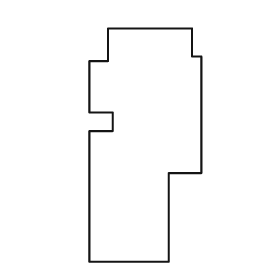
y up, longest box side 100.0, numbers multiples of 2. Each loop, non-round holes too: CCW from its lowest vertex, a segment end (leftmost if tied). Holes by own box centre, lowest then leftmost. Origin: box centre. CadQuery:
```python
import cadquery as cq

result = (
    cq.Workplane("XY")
    .moveTo(-24.0, -50.0)
    .lineTo(10.0, -50.0)
    .lineTo(10.0, -12.0)
    .lineTo(24.0, -12.0)
    .lineTo(24.0, 38.0)
    .lineTo(20.0, 38.0)
    .lineTo(20.0, 50.0)
    .lineTo(-16.0, 50.0)
    .lineTo(-16.0, 36.0)
    .lineTo(-24.0, 36.0)
    .lineTo(-24.0, 14.0)
    .lineTo(-14.0, 14.0)
    .lineTo(-14.0, 6.0)
    .lineTo(-24.0, 6.0)
    .close()
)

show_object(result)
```